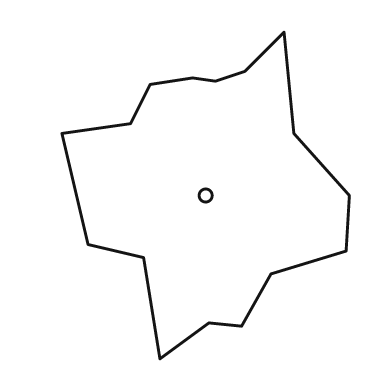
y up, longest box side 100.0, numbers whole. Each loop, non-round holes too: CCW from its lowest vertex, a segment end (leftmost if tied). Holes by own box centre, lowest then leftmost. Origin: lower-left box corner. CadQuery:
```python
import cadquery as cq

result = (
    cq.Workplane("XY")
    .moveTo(30.0, 0.0)
    .lineTo(45.0, 11.0)
    .lineTo(55.0, 10.0)
    .lineTo(64.0, 26.0)
    .lineTo(87.0, 33.0)
    .lineTo(88.0, 50.0)
    .lineTo(71.0, 69.0)
    .lineTo(68.0, 100.0)
    .lineTo(56.0, 88.0)
    .lineTo(47.0, 85.0)
    .lineTo(40.0, 86.0)
    .lineTo(27.0, 84.0)
    .lineTo(21.0, 72.0)
    .lineTo(0.0, 69.0)
    .lineTo(8.0, 35.0)
    .lineTo(25.0, 31.0)
    .close()
    .moveTo(44.0, 50.0)
    .circle(2.0)
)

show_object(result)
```